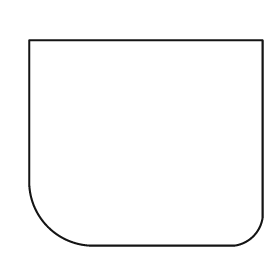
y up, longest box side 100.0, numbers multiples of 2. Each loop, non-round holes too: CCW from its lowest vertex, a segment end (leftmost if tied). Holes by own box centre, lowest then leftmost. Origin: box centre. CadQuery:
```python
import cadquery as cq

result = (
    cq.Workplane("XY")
    .moveTo(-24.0, -44.0)
    .lineTo(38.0, -44.0)
    .threePointArc((46.0, -40.0), (50.0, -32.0))
    .lineTo(50.0, 44.0)
    .lineTo(-50.0, 44.0)
    .lineTo(-50.0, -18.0)
    .threePointArc((-42.0, -36.0), (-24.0, -44.0))
    .close()
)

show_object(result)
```